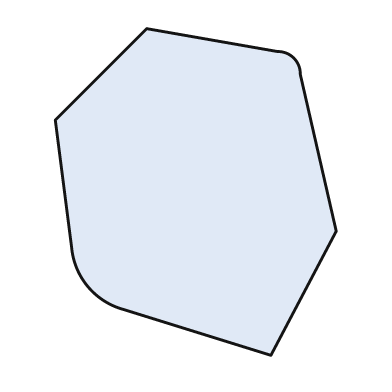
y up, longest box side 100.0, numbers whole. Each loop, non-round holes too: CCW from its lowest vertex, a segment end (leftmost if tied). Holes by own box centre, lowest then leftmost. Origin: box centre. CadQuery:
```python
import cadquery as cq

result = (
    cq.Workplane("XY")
    .moveTo(23.0, -50.0)
    .lineTo(43.0, -12.0)
    .lineTo(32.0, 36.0)
    .threePointArc((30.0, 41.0), (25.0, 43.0))
    .lineTo(-15.0, 50.0)
    .lineTo(-43.0, 22.0)
    .lineTo(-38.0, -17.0)
    .threePointArc((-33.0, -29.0), (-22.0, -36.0))
    .close()
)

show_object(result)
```